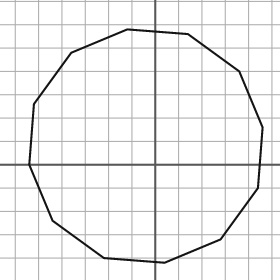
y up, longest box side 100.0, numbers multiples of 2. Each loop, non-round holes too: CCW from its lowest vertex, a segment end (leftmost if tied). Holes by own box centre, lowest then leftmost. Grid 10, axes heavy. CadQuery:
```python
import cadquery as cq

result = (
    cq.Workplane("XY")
    .moveTo(4.0, -42.0)
    .lineTo(28.0, -32.0)
    .lineTo(44.0, -10.0)
    .lineTo(46.0, 16.0)
    .lineTo(36.0, 40.0)
    .lineTo(14.0, 56.0)
    .lineTo(-12.0, 58.0)
    .lineTo(-36.0, 48.0)
    .lineTo(-52.0, 26.0)
    .lineTo(-54.0, 0.0)
    .lineTo(-44.0, -24.0)
    .lineTo(-22.0, -40.0)
    .close()
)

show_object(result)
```